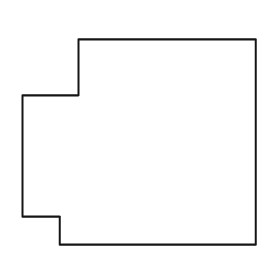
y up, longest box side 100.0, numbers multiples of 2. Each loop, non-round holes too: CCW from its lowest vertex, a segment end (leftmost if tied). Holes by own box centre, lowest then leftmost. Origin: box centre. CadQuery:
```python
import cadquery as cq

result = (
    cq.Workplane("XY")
    .moveTo(-34.0, -44.0)
    .lineTo(50.0, -44.0)
    .lineTo(50.0, 44.0)
    .lineTo(-26.0, 44.0)
    .lineTo(-26.0, 20.0)
    .lineTo(-50.0, 20.0)
    .lineTo(-50.0, -32.0)
    .lineTo(-34.0, -32.0)
    .close()
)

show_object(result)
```